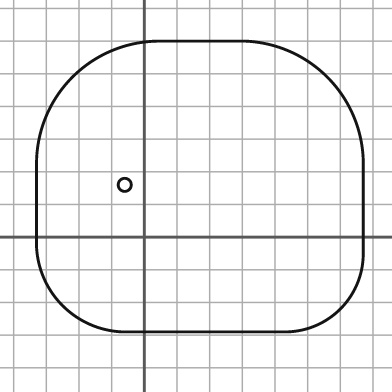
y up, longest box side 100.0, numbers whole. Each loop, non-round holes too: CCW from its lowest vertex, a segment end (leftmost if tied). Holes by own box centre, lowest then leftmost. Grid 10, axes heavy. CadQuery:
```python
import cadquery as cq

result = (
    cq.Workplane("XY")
    .moveTo(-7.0, -29.0)
    .lineTo(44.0, -29.0)
    .threePointArc((60.0, -22.0), (67.0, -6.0))
    .lineTo(67.0, 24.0)
    .threePointArc((56.0, 49.0), (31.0, 60.0))
    .lineTo(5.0, 60.0)
    .threePointArc((-22.0, 49.0), (-33.0, 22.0))
    .lineTo(-33.0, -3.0)
    .threePointArc((-25.0, -21.0), (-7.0, -29.0))
    .close()
    .moveTo(-6.0, 16.0)
    .circle(2.0)
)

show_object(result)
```